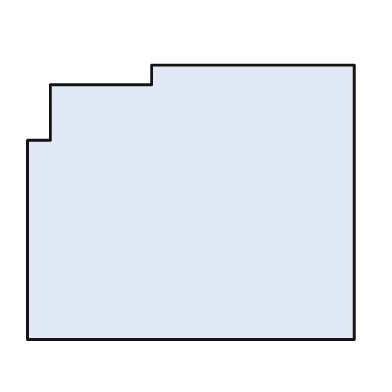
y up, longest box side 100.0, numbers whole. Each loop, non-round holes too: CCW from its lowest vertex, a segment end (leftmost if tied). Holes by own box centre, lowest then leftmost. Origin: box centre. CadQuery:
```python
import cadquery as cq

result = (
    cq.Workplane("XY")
    .moveTo(-50.0, -42.0)
    .lineTo(50.0, -42.0)
    .lineTo(50.0, 42.0)
    .lineTo(-12.0, 42.0)
    .lineTo(-12.0, 36.0)
    .lineTo(-43.0, 36.0)
    .lineTo(-43.0, 19.0)
    .lineTo(-50.0, 19.0)
    .close()
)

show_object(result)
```